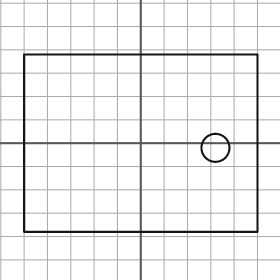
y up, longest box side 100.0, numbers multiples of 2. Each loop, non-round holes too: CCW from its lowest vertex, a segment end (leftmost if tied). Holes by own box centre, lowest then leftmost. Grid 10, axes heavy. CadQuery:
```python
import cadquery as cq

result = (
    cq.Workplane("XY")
    .moveTo(-50.0, -38.0)
    .lineTo(50.0, -38.0)
    .lineTo(50.0, 38.0)
    .lineTo(-50.0, 38.0)
    .close()
    .moveTo(32.0, -2.0)
    .circle(6.0)
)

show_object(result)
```